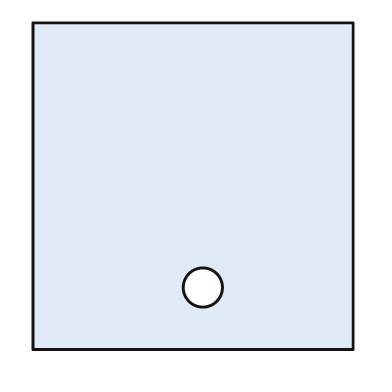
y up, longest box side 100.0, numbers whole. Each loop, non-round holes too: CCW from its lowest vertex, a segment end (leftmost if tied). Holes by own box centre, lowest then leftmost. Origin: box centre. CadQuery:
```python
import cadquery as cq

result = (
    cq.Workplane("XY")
    .moveTo(-49.0, -50.0)
    .lineTo(49.0, -50.0)
    .lineTo(49.0, 50.0)
    .lineTo(-49.0, 50.0)
    .close()
    .moveTo(3.0, -31.0)
    .circle(6.0)
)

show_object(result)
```